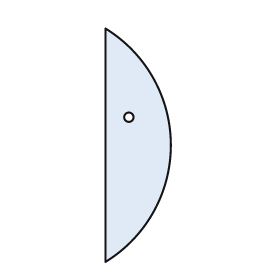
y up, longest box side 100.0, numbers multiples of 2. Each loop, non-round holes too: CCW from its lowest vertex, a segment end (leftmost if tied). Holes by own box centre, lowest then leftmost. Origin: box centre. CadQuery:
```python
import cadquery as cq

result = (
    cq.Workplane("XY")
    .moveTo(-14.0, -50.0)
    .threePointArc((14.0, 0.0), (-14.0, 50.0))
    .close()
    .moveTo(-4.0, 12.0)
    .circle(2.0)
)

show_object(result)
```